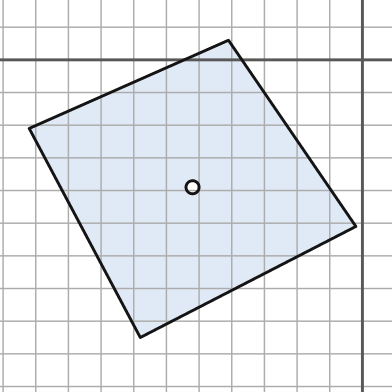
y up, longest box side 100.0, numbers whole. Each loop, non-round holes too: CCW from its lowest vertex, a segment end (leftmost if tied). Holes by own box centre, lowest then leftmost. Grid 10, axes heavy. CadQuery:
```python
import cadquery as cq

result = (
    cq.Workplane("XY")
    .moveTo(-68.0, -85.0)
    .lineTo(-2.0, -51.0)
    .lineTo(-41.0, 6.0)
    .lineTo(-102.0, -21.0)
    .close()
    .moveTo(-52.0, -39.0)
    .circle(2.0)
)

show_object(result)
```